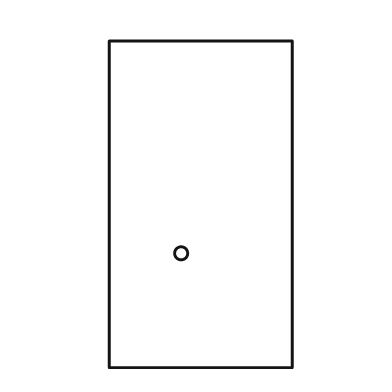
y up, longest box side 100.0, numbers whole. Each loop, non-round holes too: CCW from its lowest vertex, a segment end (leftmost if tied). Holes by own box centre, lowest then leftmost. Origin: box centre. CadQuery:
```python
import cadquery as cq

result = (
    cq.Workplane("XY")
    .moveTo(-28.0, -50.0)
    .lineTo(28.0, -50.0)
    .lineTo(28.0, 50.0)
    .lineTo(-28.0, 50.0)
    .close()
    .moveTo(-6.0, -15.0)
    .circle(2.0)
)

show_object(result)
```